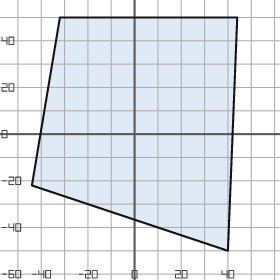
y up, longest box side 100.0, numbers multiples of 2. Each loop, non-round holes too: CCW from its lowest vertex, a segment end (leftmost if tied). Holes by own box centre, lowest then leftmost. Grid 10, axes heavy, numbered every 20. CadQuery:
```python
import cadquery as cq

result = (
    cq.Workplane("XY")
    .moveTo(40.0, -50.0)
    .lineTo(44.0, 50.0)
    .lineTo(-32.0, 50.0)
    .lineTo(-44.0, -22.0)
    .close()
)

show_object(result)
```